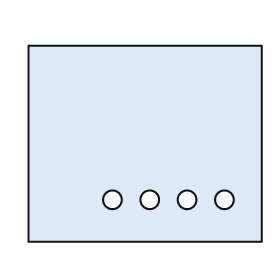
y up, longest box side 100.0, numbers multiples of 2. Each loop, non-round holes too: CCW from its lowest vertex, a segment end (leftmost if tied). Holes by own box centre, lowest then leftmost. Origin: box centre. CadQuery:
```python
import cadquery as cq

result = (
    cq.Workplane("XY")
    .moveTo(-50.0, -42.0)
    .lineTo(50.0, -42.0)
    .lineTo(50.0, 42.0)
    .lineTo(-50.0, 42.0)
    .close()
    .moveTo(-14.0, -24.0)
    .circle(4.0)
    .moveTo(2.0, -24.0)
    .circle(4.0)
    .moveTo(18.0, -24.0)
    .circle(4.0)
    .moveTo(34.0, -24.0)
    .circle(4.0)
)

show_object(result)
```